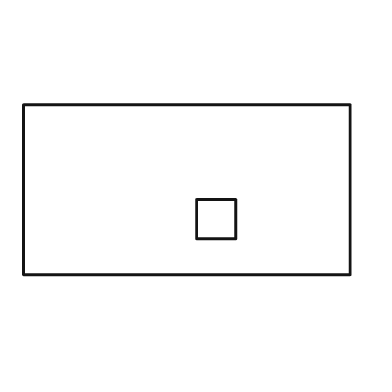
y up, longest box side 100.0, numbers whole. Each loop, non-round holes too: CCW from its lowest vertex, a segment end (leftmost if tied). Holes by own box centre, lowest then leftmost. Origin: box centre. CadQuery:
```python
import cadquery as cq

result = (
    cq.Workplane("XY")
    .moveTo(-50.0, -26.0)
    .lineTo(50.0, -26.0)
    .lineTo(50.0, 26.0)
    .lineTo(-50.0, 26.0)
    .close()
    .moveTo(3.0, -15.0)
    .lineTo(15.0, -15.0)
    .lineTo(15.0, -3.0)
    .lineTo(3.0, -3.0)
    .close()
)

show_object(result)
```